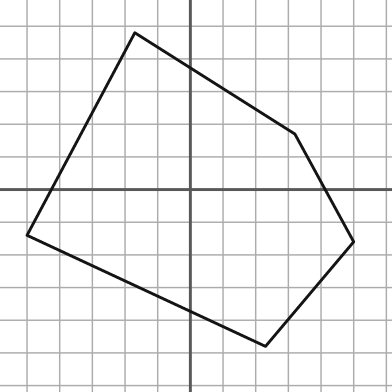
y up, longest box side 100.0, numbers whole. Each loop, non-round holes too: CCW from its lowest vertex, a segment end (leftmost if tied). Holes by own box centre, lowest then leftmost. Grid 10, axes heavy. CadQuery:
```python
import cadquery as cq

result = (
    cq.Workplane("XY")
    .moveTo(23.0, -48.0)
    .lineTo(50.0, -16.0)
    .lineTo(32.0, 17.0)
    .lineTo(-17.0, 48.0)
    .lineTo(-50.0, -14.0)
    .close()
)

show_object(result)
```